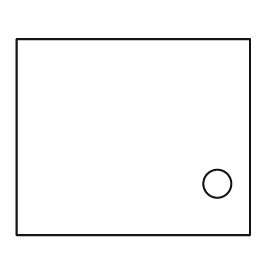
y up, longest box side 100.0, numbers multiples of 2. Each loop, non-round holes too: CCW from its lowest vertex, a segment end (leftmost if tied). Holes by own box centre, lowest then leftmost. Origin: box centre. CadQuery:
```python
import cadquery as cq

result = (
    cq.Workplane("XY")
    .moveTo(-50.0, -42.0)
    .lineTo(50.0, -42.0)
    .lineTo(50.0, 42.0)
    .lineTo(-50.0, 42.0)
    .close()
    .moveTo(36.0, -20.0)
    .circle(6.0)
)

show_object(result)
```